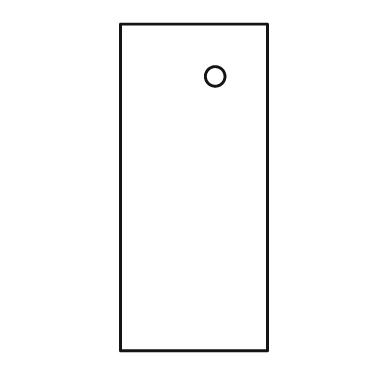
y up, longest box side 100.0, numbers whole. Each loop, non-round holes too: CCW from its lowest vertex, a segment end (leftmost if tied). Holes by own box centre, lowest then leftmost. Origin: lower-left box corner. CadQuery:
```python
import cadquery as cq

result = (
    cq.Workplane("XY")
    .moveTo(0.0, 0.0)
    .lineTo(45.0, 0.0)
    .lineTo(45.0, 100.0)
    .lineTo(0.0, 100.0)
    .close()
    .moveTo(29.0, 84.0)
    .circle(3.0)
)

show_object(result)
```